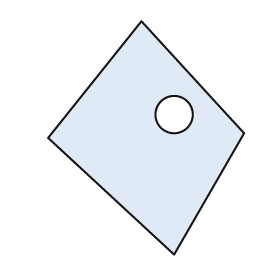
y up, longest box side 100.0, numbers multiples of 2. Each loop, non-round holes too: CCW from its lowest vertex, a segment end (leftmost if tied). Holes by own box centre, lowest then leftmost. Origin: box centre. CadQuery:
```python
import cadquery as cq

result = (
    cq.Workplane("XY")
    .moveTo(12.0, -50.0)
    .lineTo(42.0, 2.0)
    .lineTo(-2.0, 50.0)
    .lineTo(-42.0, 0.0)
    .close()
    .moveTo(12.0, 10.0)
    .circle(8.0)
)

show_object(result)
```